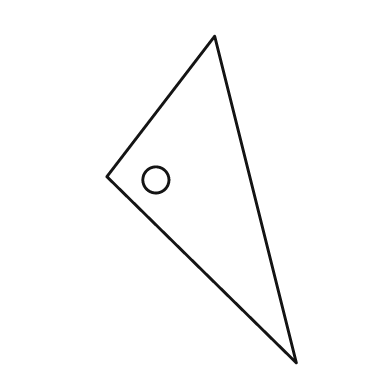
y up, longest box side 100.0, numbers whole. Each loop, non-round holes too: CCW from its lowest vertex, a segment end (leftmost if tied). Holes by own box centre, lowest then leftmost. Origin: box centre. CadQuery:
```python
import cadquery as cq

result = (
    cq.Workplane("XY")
    .moveTo(29.0, -50.0)
    .lineTo(4.0, 50.0)
    .lineTo(-29.0, 7.0)
    .close()
    .moveTo(-14.0, 6.0)
    .circle(4.0)
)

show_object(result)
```